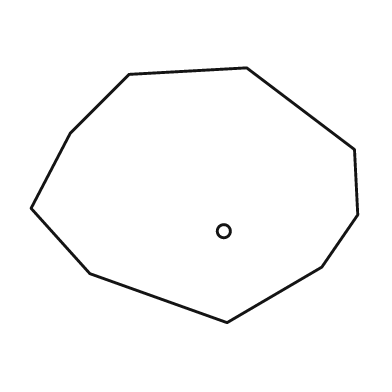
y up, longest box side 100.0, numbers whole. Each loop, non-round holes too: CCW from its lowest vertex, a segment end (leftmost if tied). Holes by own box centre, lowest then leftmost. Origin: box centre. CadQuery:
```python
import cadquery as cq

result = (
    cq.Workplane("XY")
    .moveTo(10.0, -39.0)
    .lineTo(39.0, -22.0)
    .lineTo(50.0, -6.0)
    .lineTo(49.0, 14.0)
    .lineTo(16.0, 39.0)
    .lineTo(-20.0, 37.0)
    .lineTo(-38.0, 19.0)
    .lineTo(-50.0, -4.0)
    .lineTo(-32.0, -24.0)
    .close()
    .moveTo(9.0, -11.0)
    .circle(2.0)
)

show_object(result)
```